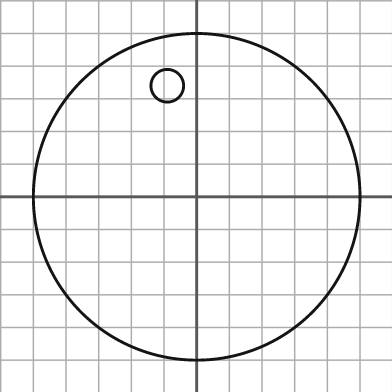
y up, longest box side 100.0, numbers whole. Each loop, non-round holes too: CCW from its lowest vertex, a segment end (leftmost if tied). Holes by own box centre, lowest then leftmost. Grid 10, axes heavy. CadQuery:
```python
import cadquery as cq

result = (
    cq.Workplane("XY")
    .moveTo(0.0, 0.0)
    .circle(50.0)
    .moveTo(-9.0, 34.0)
    .circle(5.0)
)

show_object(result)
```